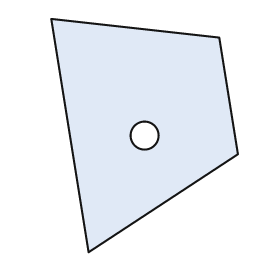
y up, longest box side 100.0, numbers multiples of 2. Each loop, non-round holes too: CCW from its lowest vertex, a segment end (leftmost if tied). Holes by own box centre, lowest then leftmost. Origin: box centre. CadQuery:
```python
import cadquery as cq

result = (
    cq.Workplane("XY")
    .moveTo(-24.0, -50.0)
    .lineTo(40.0, -8.0)
    .lineTo(32.0, 42.0)
    .lineTo(-40.0, 50.0)
    .close()
    .moveTo(0.0, 0.0)
    .circle(6.0)
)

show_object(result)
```